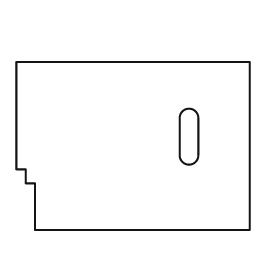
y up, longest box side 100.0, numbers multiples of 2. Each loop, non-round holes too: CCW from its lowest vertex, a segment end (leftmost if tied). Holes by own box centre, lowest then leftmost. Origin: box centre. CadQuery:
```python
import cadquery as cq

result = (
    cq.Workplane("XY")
    .moveTo(-42.0, -36.0)
    .lineTo(50.0, -36.0)
    .lineTo(50.0, 36.0)
    .lineTo(-50.0, 36.0)
    .lineTo(-50.0, -10.0)
    .lineTo(-46.0, -10.0)
    .lineTo(-46.0, -16.0)
    .lineTo(-42.0, -16.0)
    .close()
    .moveTo(20.0, -4.0)
    .threePointArc((24.0, -8.0), (28.0, -4.0))
    .lineTo(28.0, 12.0)
    .threePointArc((24.0, 16.0), (20.0, 12.0))
    .close()
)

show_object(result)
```